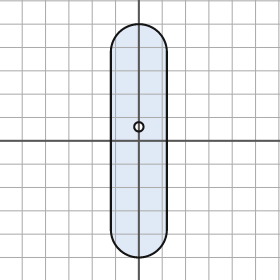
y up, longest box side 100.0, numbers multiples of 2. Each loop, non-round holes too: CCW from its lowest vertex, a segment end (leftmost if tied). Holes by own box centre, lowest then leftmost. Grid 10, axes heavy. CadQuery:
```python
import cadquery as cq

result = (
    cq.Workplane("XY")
    .moveTo(-12.0, -38.0)
    .threePointArc((0.0, -50.0), (12.0, -38.0))
    .lineTo(12.0, 38.0)
    .threePointArc((0.0, 50.0), (-12.0, 38.0))
    .close()
    .moveTo(0.0, 6.0)
    .circle(2.0)
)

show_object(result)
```